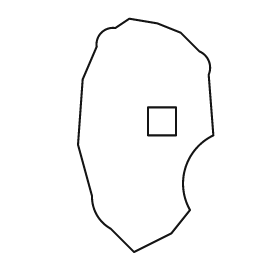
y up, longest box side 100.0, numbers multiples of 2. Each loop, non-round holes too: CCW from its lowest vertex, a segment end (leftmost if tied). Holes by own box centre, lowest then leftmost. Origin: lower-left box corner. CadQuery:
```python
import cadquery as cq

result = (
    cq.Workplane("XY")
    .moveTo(24.0, 0.0)
    .lineTo(40.0, 8.0)
    .lineTo(48.0, 18.0)
    .threePointArc((46.0, 36.0), (58.0, 50.0))
    .lineTo(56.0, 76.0)
    .threePointArc((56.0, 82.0), (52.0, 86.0))
    .lineTo(44.0, 94.0)
    .lineTo(34.0, 98.0)
    .lineTo(22.0, 100.0)
    .lineTo(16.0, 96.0)
    .threePointArc((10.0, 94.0), (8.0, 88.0))
    .lineTo(2.0, 74.0)
    .lineTo(0.0, 46.0)
    .lineTo(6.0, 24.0)
    .threePointArc((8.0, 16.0), (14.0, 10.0))
    .close()
    .moveTo(30.0, 50.0)
    .lineTo(42.0, 50.0)
    .lineTo(42.0, 62.0)
    .lineTo(30.0, 62.0)
    .close()
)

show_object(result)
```